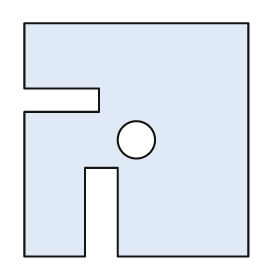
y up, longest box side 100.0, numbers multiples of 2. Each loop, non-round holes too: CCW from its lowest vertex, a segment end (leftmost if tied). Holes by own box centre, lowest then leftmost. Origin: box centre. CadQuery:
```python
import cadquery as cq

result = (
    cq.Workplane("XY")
    .moveTo(-48.0, -50.0)
    .lineTo(-22.0, -50.0)
    .lineTo(-22.0, -12.0)
    .lineTo(-8.0, -12.0)
    .lineTo(-8.0, -50.0)
    .lineTo(48.0, -50.0)
    .lineTo(48.0, 50.0)
    .lineTo(-48.0, 50.0)
    .lineTo(-48.0, 22.0)
    .lineTo(-16.0, 22.0)
    .lineTo(-16.0, 12.0)
    .lineTo(-48.0, 12.0)
    .close()
    .moveTo(0.0, 0.0)
    .circle(8.0)
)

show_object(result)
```